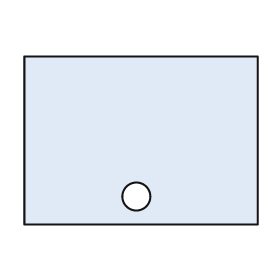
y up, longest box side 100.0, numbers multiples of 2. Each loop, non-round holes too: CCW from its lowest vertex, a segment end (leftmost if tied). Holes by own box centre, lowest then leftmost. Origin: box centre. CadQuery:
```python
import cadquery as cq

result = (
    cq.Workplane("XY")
    .moveTo(-50.0, -36.0)
    .lineTo(50.0, -36.0)
    .lineTo(50.0, 36.0)
    .lineTo(-50.0, 36.0)
    .close()
    .moveTo(-2.0, -24.0)
    .circle(6.0)
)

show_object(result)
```